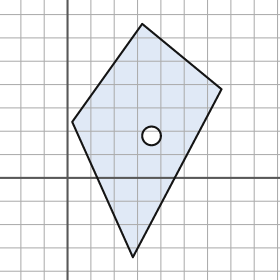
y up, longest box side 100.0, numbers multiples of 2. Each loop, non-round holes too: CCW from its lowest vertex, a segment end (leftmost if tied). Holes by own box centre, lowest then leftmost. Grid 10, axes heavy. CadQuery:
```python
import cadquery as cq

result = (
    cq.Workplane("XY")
    .moveTo(28.0, -34.0)
    .lineTo(66.0, 38.0)
    .lineTo(32.0, 66.0)
    .lineTo(2.0, 24.0)
    .close()
    .moveTo(36.0, 18.0)
    .circle(4.0)
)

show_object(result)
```